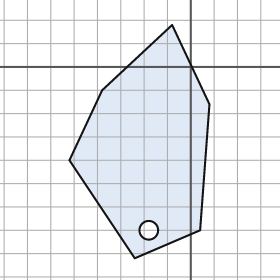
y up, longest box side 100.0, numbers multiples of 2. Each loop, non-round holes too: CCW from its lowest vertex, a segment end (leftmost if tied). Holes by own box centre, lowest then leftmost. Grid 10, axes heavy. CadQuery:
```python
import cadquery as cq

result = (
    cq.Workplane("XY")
    .moveTo(-24.0, -82.0)
    .lineTo(4.0, -70.0)
    .lineTo(8.0, -16.0)
    .lineTo(-8.0, 18.0)
    .lineTo(-38.0, -10.0)
    .lineTo(-52.0, -40.0)
    .close()
    .moveTo(-18.0, -70.0)
    .circle(4.0)
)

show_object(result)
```